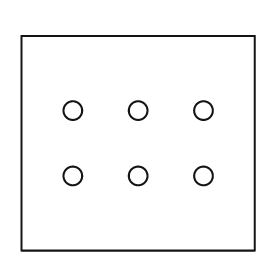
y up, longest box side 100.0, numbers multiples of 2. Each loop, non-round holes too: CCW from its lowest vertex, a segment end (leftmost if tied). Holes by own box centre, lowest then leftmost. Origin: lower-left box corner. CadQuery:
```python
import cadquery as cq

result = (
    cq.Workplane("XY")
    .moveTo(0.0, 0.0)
    .lineTo(100.0, 0.0)
    .lineTo(100.0, 92.0)
    .lineTo(0.0, 92.0)
    .close()
    .moveTo(22.0, 32.0)
    .circle(4.0)
    .moveTo(50.0, 32.0)
    .circle(4.0)
    .moveTo(78.0, 32.0)
    .circle(4.0)
    .moveTo(22.0, 60.0)
    .circle(4.0)
    .moveTo(50.0, 60.0)
    .circle(4.0)
    .moveTo(78.0, 60.0)
    .circle(4.0)
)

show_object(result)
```